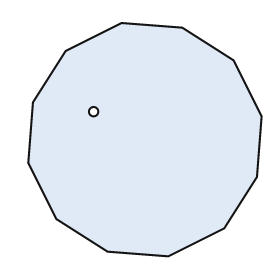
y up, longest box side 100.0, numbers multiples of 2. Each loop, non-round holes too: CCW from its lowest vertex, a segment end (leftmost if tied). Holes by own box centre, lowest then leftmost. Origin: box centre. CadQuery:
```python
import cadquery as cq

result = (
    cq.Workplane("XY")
    .moveTo(10.0, -50.0)
    .lineTo(34.0, -38.0)
    .lineTo(48.0, -16.0)
    .lineTo(50.0, 10.0)
    .lineTo(38.0, 34.0)
    .lineTo(16.0, 48.0)
    .lineTo(-10.0, 50.0)
    .lineTo(-34.0, 38.0)
    .lineTo(-48.0, 16.0)
    .lineTo(-50.0, -10.0)
    .lineTo(-38.0, -34.0)
    .lineTo(-16.0, -48.0)
    .close()
    .moveTo(-22.0, 12.0)
    .circle(2.0)
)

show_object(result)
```